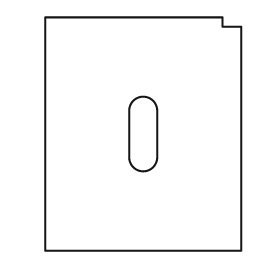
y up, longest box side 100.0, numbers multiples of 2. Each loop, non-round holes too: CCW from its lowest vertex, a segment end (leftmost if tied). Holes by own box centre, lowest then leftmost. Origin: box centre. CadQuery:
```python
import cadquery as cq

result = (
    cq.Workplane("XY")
    .moveTo(-42.0, -50.0)
    .lineTo(42.0, -50.0)
    .lineTo(42.0, 46.0)
    .lineTo(34.0, 46.0)
    .lineTo(34.0, 50.0)
    .lineTo(-42.0, 50.0)
    .close()
    .moveTo(-6.0, -10.0)
    .threePointArc((0.0, -16.0), (6.0, -10.0))
    .lineTo(6.0, 10.0)
    .threePointArc((0.0, 16.0), (-6.0, 10.0))
    .close()
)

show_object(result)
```